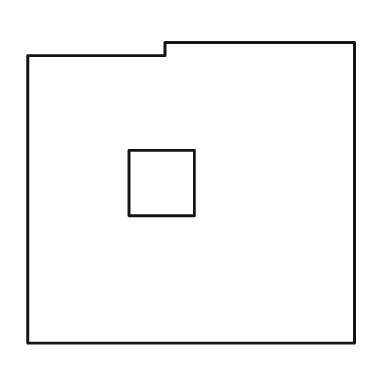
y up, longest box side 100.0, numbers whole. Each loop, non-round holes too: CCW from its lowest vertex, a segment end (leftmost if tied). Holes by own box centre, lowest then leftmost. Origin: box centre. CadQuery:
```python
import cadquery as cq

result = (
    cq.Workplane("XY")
    .moveTo(-50.0, -46.0)
    .lineTo(50.0, -46.0)
    .lineTo(50.0, 46.0)
    .lineTo(-8.0, 46.0)
    .lineTo(-8.0, 42.0)
    .lineTo(-50.0, 42.0)
    .close()
    .moveTo(-19.0, -7.0)
    .lineTo(1.0, -7.0)
    .lineTo(1.0, 13.0)
    .lineTo(-19.0, 13.0)
    .close()
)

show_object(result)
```